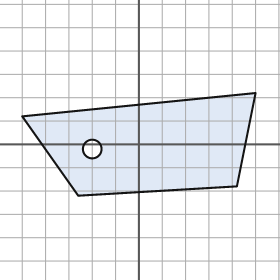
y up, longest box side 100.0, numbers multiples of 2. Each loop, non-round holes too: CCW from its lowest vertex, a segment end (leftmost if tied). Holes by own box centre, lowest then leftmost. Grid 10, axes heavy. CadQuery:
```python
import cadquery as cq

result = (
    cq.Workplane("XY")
    .moveTo(-26.0, -22.0)
    .lineTo(42.0, -18.0)
    .lineTo(50.0, 22.0)
    .lineTo(-50.0, 12.0)
    .close()
    .moveTo(-20.0, -2.0)
    .circle(4.0)
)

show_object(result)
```